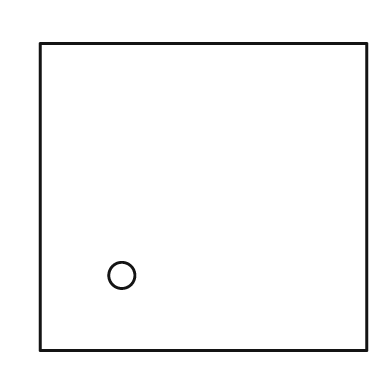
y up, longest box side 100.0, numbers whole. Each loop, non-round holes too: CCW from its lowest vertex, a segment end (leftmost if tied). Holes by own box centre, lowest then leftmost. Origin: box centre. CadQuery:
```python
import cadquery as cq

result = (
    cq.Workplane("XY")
    .moveTo(-50.0, -47.0)
    .lineTo(50.0, -47.0)
    .lineTo(50.0, 47.0)
    .lineTo(-50.0, 47.0)
    .close()
    .moveTo(-25.0, -24.0)
    .circle(4.0)
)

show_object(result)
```